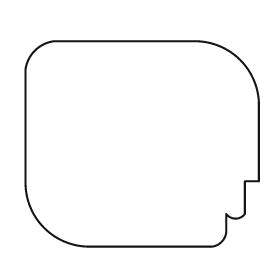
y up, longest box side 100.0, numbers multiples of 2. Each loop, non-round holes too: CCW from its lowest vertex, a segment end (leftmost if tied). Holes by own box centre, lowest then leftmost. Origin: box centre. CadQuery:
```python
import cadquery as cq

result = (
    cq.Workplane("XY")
    .moveTo(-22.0, -44.0)
    .lineTo(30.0, -44.0)
    .threePointArc((34.0, -42.0), (36.0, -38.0))
    .lineTo(36.0, -30.0)
    .threePointArc((40.0, -32.0), (44.0, -30.0))
    .lineTo(44.0, -16.0)
    .lineTo(50.0, -16.0)
    .lineTo(50.0, 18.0)
    .threePointArc((42.0, 36.0), (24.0, 44.0))
    .lineTo(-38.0, 44.0)
    .threePointArc((-46.0, 40.0), (-50.0, 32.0))
    .lineTo(-50.0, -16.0)
    .threePointArc((-42.0, -36.0), (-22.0, -44.0))
    .close()
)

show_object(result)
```